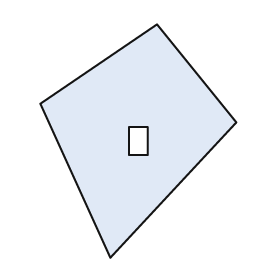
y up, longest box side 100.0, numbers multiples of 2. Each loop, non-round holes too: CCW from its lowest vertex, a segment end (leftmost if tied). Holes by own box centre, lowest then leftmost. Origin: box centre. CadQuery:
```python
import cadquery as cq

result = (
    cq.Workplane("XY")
    .moveTo(-12.0, -50.0)
    .lineTo(42.0, 8.0)
    .lineTo(8.0, 50.0)
    .lineTo(-42.0, 16.0)
    .close()
    .moveTo(-4.0, -6.0)
    .lineTo(4.0, -6.0)
    .lineTo(4.0, 6.0)
    .lineTo(-4.0, 6.0)
    .close()
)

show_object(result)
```